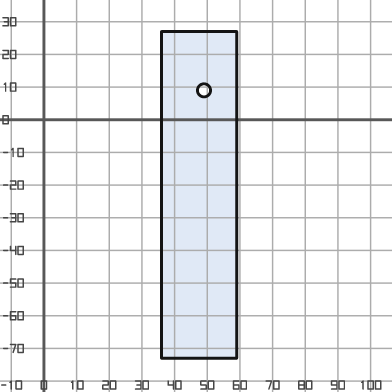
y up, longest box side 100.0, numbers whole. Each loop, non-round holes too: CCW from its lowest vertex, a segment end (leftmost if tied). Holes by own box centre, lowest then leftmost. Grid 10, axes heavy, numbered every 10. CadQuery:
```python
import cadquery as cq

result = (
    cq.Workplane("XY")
    .moveTo(36.0, -73.0)
    .lineTo(59.0, -73.0)
    .lineTo(59.0, 27.0)
    .lineTo(36.0, 27.0)
    .close()
    .moveTo(49.0, 9.0)
    .circle(2.0)
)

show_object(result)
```